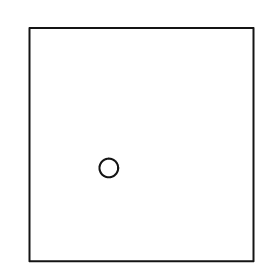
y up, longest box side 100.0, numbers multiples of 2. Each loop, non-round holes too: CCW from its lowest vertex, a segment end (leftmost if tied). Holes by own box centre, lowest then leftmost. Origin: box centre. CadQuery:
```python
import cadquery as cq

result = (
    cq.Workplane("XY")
    .moveTo(-48.0, -50.0)
    .lineTo(48.0, -50.0)
    .lineTo(48.0, 50.0)
    .lineTo(-48.0, 50.0)
    .close()
    .moveTo(-14.0, -10.0)
    .circle(4.0)
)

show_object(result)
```